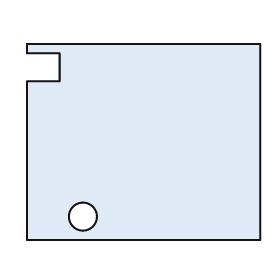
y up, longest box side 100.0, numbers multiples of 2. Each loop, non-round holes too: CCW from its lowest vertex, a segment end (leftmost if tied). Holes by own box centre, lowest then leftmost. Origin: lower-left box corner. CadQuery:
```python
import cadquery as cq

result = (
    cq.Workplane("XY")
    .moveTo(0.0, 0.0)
    .lineTo(100.0, 0.0)
    .lineTo(100.0, 84.0)
    .lineTo(0.0, 84.0)
    .lineTo(0.0, 80.0)
    .lineTo(14.0, 80.0)
    .lineTo(14.0, 68.0)
    .lineTo(0.0, 68.0)
    .close()
    .moveTo(24.0, 10.0)
    .circle(6.0)
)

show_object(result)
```